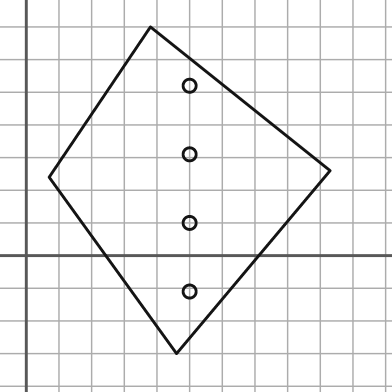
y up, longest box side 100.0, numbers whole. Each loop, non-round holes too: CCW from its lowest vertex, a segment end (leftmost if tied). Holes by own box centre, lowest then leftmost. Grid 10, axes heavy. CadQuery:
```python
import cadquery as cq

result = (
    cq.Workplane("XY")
    .moveTo(46.0, -30.0)
    .lineTo(93.0, 26.0)
    .lineTo(38.0, 70.0)
    .lineTo(7.0, 24.0)
    .close()
    .moveTo(50.0, -11.0)
    .circle(2.0)
    .moveTo(50.0, 10.0)
    .circle(2.0)
    .moveTo(50.0, 31.0)
    .circle(2.0)
    .moveTo(50.0, 52.0)
    .circle(2.0)
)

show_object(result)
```